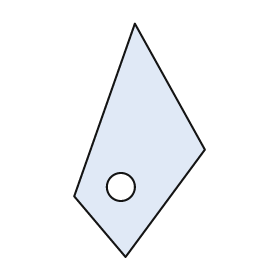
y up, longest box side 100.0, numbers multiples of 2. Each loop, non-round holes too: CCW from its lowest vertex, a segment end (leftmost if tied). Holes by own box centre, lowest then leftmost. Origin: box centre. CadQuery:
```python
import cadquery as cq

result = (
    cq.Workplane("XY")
    .moveTo(-6.0, -50.0)
    .lineTo(28.0, -4.0)
    .lineTo(-2.0, 50.0)
    .lineTo(-28.0, -24.0)
    .close()
    .moveTo(-8.0, -20.0)
    .circle(6.0)
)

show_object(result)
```